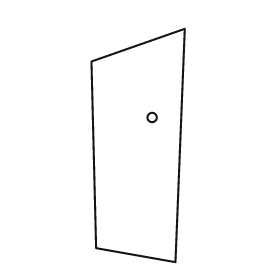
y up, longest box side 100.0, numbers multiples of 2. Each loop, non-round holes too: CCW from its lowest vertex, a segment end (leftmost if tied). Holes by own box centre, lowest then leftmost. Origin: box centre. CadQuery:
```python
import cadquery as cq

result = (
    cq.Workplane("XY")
    .moveTo(16.0, -50.0)
    .lineTo(20.0, 50.0)
    .lineTo(-20.0, 36.0)
    .lineTo(-18.0, -44.0)
    .close()
    .moveTo(6.0, 12.0)
    .circle(2.0)
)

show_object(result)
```